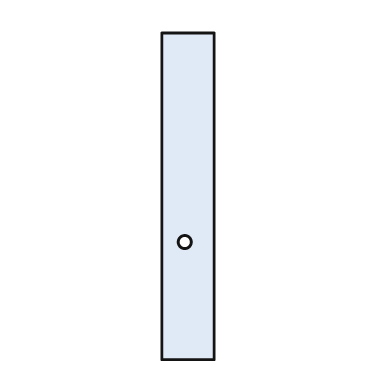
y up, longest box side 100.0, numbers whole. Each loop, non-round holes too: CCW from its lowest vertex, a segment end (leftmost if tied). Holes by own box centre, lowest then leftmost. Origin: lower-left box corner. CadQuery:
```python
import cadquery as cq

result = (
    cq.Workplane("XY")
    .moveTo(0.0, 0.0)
    .lineTo(16.0, 0.0)
    .lineTo(16.0, 100.0)
    .lineTo(0.0, 100.0)
    .close()
    .moveTo(7.0, 36.0)
    .circle(2.0)
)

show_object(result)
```